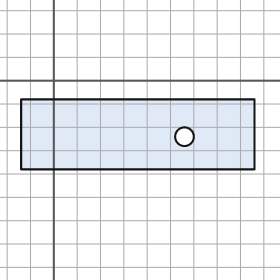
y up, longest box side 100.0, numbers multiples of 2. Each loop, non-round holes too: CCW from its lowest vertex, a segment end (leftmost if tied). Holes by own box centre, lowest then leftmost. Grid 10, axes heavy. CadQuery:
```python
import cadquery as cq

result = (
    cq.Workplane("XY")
    .moveTo(-14.0, -38.0)
    .lineTo(86.0, -38.0)
    .lineTo(86.0, -8.0)
    .lineTo(-14.0, -8.0)
    .close()
    .moveTo(56.0, -24.0)
    .circle(4.0)
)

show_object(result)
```